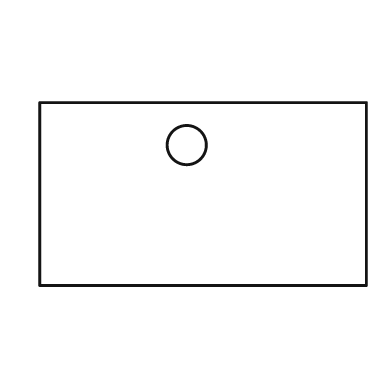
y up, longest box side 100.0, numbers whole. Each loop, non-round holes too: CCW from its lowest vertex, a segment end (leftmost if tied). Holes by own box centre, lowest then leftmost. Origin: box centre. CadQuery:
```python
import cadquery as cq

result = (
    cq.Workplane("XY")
    .moveTo(-50.0, -28.0)
    .lineTo(50.0, -28.0)
    .lineTo(50.0, 28.0)
    .lineTo(-50.0, 28.0)
    .close()
    .moveTo(-5.0, 15.0)
    .circle(6.0)
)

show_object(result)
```